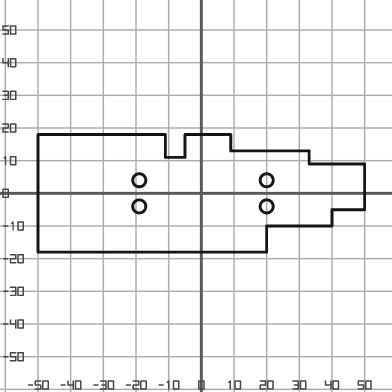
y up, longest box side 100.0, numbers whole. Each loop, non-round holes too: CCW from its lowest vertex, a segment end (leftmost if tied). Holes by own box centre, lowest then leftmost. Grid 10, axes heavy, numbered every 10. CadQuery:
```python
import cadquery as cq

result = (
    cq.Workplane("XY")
    .moveTo(-50.0, -18.0)
    .lineTo(20.0, -18.0)
    .lineTo(20.0, -10.0)
    .lineTo(40.0, -10.0)
    .lineTo(40.0, -5.0)
    .lineTo(50.0, -5.0)
    .lineTo(50.0, 9.0)
    .lineTo(33.0, 9.0)
    .lineTo(33.0, 13.0)
    .lineTo(9.0, 13.0)
    .lineTo(9.0, 18.0)
    .lineTo(-5.0, 18.0)
    .lineTo(-5.0, 11.0)
    .lineTo(-11.0, 11.0)
    .lineTo(-11.0, 18.0)
    .lineTo(-50.0, 18.0)
    .close()
    .moveTo(-19.0, -4.0)
    .circle(2.0)
    .moveTo(20.0, -4.0)
    .circle(2.0)
    .moveTo(-19.0, 4.0)
    .circle(2.0)
    .moveTo(20.0, 4.0)
    .circle(2.0)
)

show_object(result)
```